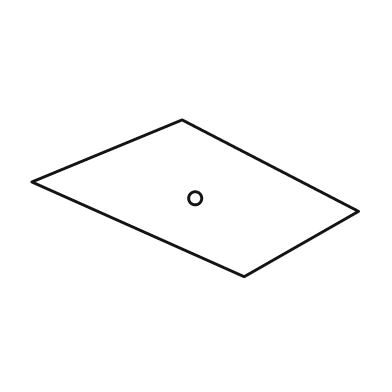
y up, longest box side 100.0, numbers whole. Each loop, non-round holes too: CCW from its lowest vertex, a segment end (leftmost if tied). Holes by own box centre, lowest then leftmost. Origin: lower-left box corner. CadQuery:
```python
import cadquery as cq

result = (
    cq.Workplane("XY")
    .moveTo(65.0, 0.0)
    .lineTo(100.0, 20.0)
    .lineTo(46.0, 48.0)
    .lineTo(0.0, 29.0)
    .close()
    .moveTo(50.0, 24.0)
    .circle(2.0)
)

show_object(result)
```